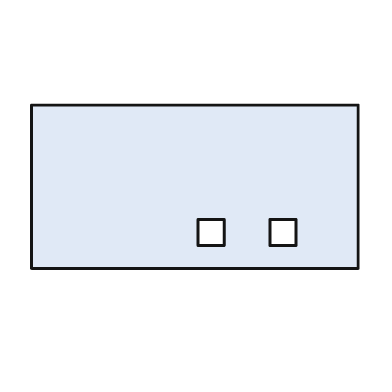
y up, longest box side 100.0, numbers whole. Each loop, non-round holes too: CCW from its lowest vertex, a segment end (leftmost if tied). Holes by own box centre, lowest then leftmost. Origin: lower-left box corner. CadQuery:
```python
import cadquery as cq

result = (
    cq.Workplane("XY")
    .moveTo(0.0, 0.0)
    .lineTo(100.0, 0.0)
    .lineTo(100.0, 50.0)
    .lineTo(0.0, 50.0)
    .close()
    .moveTo(51.0, 7.0)
    .lineTo(59.0, 7.0)
    .lineTo(59.0, 15.0)
    .lineTo(51.0, 15.0)
    .close()
    .moveTo(73.0, 7.0)
    .lineTo(81.0, 7.0)
    .lineTo(81.0, 15.0)
    .lineTo(73.0, 15.0)
    .close()
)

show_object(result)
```